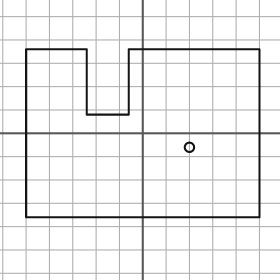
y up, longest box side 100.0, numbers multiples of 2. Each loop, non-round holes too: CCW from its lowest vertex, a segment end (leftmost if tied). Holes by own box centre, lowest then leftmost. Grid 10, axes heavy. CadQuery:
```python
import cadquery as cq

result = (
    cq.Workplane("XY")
    .moveTo(-50.0, -36.0)
    .lineTo(50.0, -36.0)
    .lineTo(50.0, 36.0)
    .lineTo(-6.0, 36.0)
    .lineTo(-6.0, 8.0)
    .lineTo(-24.0, 8.0)
    .lineTo(-24.0, 36.0)
    .lineTo(-50.0, 36.0)
    .close()
    .moveTo(20.0, -6.0)
    .circle(2.0)
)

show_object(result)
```